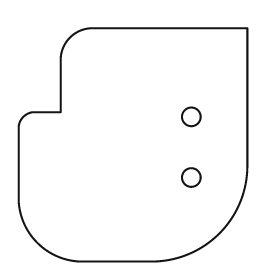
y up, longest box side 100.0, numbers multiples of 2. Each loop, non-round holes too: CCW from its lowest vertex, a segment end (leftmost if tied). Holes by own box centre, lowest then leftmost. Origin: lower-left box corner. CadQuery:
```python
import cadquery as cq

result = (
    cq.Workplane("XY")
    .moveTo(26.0, 0.0)
    .lineTo(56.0, 0.0)
    .threePointArc((86.0, 12.0), (98.0, 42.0))
    .lineTo(98.0, 100.0)
    .lineTo(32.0, 100.0)
    .threePointArc((22.0, 96.0), (18.0, 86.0))
    .lineTo(18.0, 64.0)
    .lineTo(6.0, 64.0)
    .threePointArc((2.0, 62.0), (0.0, 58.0))
    .lineTo(0.0, 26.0)
    .threePointArc((8.0, 8.0), (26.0, 0.0))
    .close()
    .moveTo(74.0, 36.0)
    .circle(4.0)
    .moveTo(74.0, 62.0)
    .circle(4.0)
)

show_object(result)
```